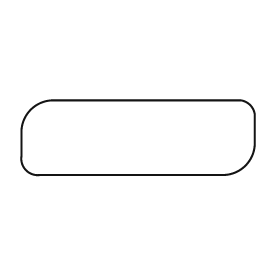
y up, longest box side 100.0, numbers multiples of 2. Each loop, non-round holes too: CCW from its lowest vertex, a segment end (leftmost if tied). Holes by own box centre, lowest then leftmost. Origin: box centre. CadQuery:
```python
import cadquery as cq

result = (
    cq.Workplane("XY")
    .moveTo(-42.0, -16.0)
    .lineTo(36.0, -16.0)
    .threePointArc((46.0, -12.0), (50.0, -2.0))
    .lineTo(50.0, 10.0)
    .threePointArc((48.0, 14.0), (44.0, 16.0))
    .lineTo(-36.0, 16.0)
    .threePointArc((-46.0, 12.0), (-50.0, 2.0))
    .lineTo(-50.0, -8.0)
    .threePointArc((-48.0, -14.0), (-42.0, -16.0))
    .close()
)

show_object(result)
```